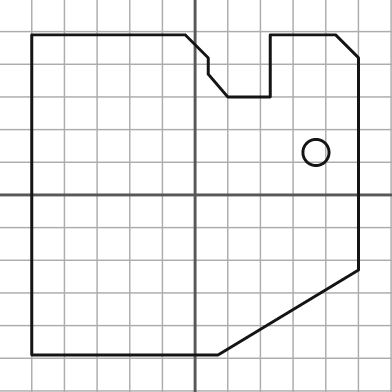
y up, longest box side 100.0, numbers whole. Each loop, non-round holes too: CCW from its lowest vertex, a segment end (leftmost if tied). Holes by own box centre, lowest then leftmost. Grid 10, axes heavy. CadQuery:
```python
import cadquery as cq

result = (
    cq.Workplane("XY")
    .moveTo(-50.0, -49.0)
    .lineTo(7.0, -49.0)
    .lineTo(50.0, -23.0)
    .lineTo(50.0, 42.0)
    .lineTo(43.0, 49.0)
    .lineTo(23.0, 49.0)
    .lineTo(23.0, 30.0)
    .lineTo(10.0, 30.0)
    .lineTo(4.0, 37.0)
    .lineTo(4.0, 42.0)
    .lineTo(-3.0, 49.0)
    .lineTo(-50.0, 49.0)
    .close()
    .moveTo(37.0, 13.0)
    .circle(4.0)
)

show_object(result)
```